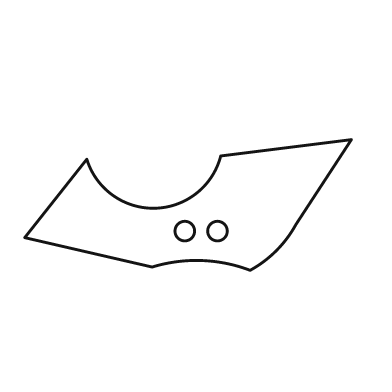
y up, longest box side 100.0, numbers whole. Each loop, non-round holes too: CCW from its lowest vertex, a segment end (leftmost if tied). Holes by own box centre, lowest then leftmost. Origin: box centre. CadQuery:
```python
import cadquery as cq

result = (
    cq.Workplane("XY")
    .moveTo(19.0, -20.0)
    .threePointArc((27.0, -14.0), (33.0, -6.0))
    .lineTo(50.0, 20.0)
    .lineTo(10.0, 15.0)
    .threePointArc((-10.0, -1.0), (-31.0, 14.0))
    .lineTo(-50.0, -10.0)
    .lineTo(-11.0, -19.0)
    .threePointArc((4.0, -17.0), (19.0, -20.0))
    .close()
    .moveTo(-1.0, -8.0)
    .circle(3.0)
    .moveTo(9.0, -8.0)
    .circle(3.0)
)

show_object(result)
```